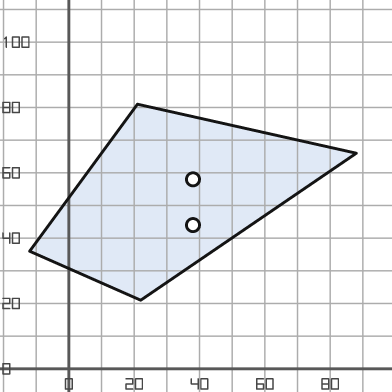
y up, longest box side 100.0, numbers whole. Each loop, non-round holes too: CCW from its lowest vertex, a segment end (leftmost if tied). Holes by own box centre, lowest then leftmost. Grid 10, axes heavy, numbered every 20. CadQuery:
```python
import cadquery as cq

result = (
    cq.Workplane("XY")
    .moveTo(22.0, 21.0)
    .lineTo(88.0, 66.0)
    .lineTo(21.0, 81.0)
    .lineTo(-12.0, 36.0)
    .close()
    .moveTo(38.0, 44.0)
    .circle(2.0)
    .moveTo(38.0, 58.0)
    .circle(2.0)
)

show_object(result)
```